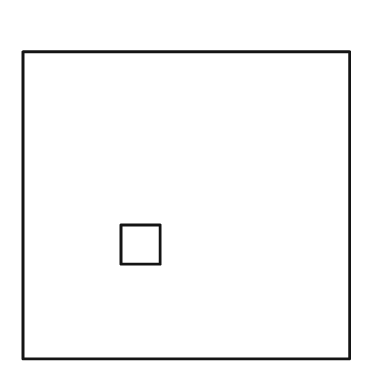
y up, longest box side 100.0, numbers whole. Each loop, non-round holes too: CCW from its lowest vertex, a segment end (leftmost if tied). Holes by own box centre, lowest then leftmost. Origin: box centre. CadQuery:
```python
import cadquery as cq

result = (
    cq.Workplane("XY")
    .moveTo(-50.0, -47.0)
    .lineTo(50.0, -47.0)
    .lineTo(50.0, 47.0)
    .lineTo(-50.0, 47.0)
    .close()
    .moveTo(-20.0, -18.0)
    .lineTo(-8.0, -18.0)
    .lineTo(-8.0, -6.0)
    .lineTo(-20.0, -6.0)
    .close()
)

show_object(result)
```